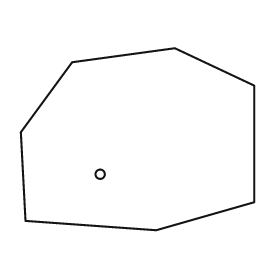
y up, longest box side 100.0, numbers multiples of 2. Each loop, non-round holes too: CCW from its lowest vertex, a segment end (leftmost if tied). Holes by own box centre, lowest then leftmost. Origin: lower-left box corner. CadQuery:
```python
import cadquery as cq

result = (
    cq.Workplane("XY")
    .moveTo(58.0, 0.0)
    .lineTo(100.0, 12.0)
    .lineTo(100.0, 62.0)
    .lineTo(66.0, 78.0)
    .lineTo(22.0, 72.0)
    .lineTo(0.0, 42.0)
    .lineTo(2.0, 4.0)
    .close()
    .moveTo(34.0, 24.0)
    .circle(2.0)
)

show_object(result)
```